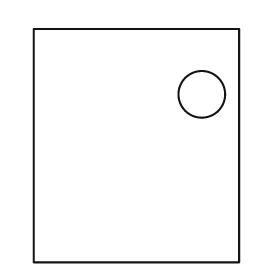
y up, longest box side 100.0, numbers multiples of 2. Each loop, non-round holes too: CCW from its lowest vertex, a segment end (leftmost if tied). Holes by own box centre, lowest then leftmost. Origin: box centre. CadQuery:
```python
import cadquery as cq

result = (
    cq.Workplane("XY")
    .moveTo(-44.0, -50.0)
    .lineTo(44.0, -50.0)
    .lineTo(44.0, 50.0)
    .lineTo(-44.0, 50.0)
    .close()
    .moveTo(28.0, 22.0)
    .circle(10.0)
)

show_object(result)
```